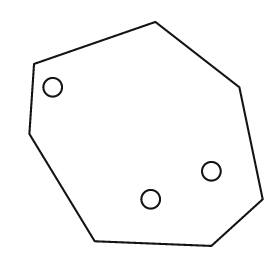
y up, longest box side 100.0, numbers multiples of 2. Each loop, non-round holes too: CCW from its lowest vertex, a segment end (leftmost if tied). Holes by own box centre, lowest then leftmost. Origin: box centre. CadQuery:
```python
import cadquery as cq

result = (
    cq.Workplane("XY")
    .moveTo(28.0, -48.0)
    .lineTo(50.0, -28.0)
    .lineTo(40.0, 20.0)
    .lineTo(4.0, 48.0)
    .lineTo(-48.0, 30.0)
    .lineTo(-50.0, 0.0)
    .lineTo(-22.0, -46.0)
    .close()
    .moveTo(2.0, -28.0)
    .circle(4.0)
    .moveTo(28.0, -16.0)
    .circle(4.0)
    .moveTo(-40.0, 20.0)
    .circle(4.0)
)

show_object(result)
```